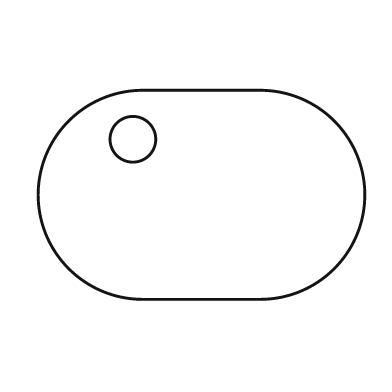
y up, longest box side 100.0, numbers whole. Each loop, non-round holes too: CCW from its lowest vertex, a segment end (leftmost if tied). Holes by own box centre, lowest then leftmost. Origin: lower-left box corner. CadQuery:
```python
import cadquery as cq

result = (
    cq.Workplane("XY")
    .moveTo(32.0, 0.0)
    .lineTo(68.0, 0.0)
    .threePointArc((100.0, 32.0), (68.0, 64.0))
    .lineTo(32.0, 64.0)
    .threePointArc((0.0, 32.0), (32.0, 0.0))
    .close()
    .moveTo(29.0, 49.0)
    .circle(7.0)
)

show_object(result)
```